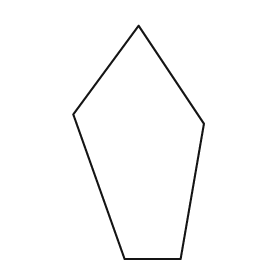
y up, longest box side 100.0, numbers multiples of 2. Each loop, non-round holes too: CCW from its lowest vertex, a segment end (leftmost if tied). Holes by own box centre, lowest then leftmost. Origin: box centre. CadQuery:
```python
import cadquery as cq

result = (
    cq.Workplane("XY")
    .moveTo(-6.0, -50.0)
    .lineTo(18.0, -50.0)
    .lineTo(28.0, 8.0)
    .lineTo(0.0, 50.0)
    .lineTo(-28.0, 12.0)
    .close()
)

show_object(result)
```